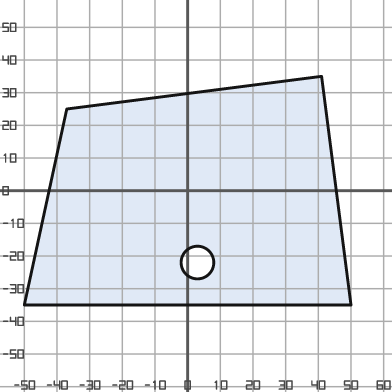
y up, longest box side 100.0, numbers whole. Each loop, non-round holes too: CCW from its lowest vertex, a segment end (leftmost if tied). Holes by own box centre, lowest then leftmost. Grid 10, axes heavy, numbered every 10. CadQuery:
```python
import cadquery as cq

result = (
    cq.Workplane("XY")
    .moveTo(-50.0, -35.0)
    .lineTo(50.0, -35.0)
    .lineTo(41.0, 35.0)
    .lineTo(-37.0, 25.0)
    .close()
    .moveTo(3.0, -22.0)
    .circle(5.0)
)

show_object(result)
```